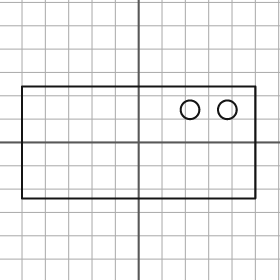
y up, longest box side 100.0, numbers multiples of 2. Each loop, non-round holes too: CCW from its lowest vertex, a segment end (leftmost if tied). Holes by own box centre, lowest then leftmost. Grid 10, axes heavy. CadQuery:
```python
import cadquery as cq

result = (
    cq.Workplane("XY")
    .moveTo(-50.0, -24.0)
    .lineTo(50.0, -24.0)
    .lineTo(50.0, 24.0)
    .lineTo(-50.0, 24.0)
    .close()
    .moveTo(22.0, 14.0)
    .circle(4.0)
    .moveTo(38.0, 14.0)
    .circle(4.0)
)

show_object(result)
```